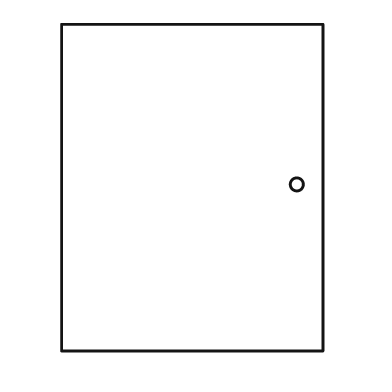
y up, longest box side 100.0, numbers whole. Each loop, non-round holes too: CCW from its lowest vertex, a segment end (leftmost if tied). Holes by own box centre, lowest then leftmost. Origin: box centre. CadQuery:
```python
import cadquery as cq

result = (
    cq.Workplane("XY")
    .moveTo(-40.0, -50.0)
    .lineTo(40.0, -50.0)
    .lineTo(40.0, 50.0)
    .lineTo(-40.0, 50.0)
    .close()
    .moveTo(32.0, 1.0)
    .circle(2.0)
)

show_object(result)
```